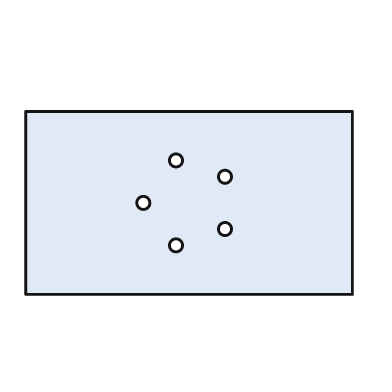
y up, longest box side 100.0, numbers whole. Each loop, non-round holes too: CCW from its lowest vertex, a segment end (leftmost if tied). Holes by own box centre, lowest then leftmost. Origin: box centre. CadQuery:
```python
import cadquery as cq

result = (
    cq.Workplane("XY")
    .moveTo(-50.0, -28.0)
    .lineTo(50.0, -28.0)
    .lineTo(50.0, 28.0)
    .lineTo(-50.0, 28.0)
    .close()
    .moveTo(-4.0, -13.0)
    .circle(2.0)
    .moveTo(11.0, -8.0)
    .circle(2.0)
    .moveTo(-14.0, 0.0)
    .circle(2.0)
    .moveTo(11.0, 8.0)
    .circle(2.0)
    .moveTo(-4.0, 13.0)
    .circle(2.0)
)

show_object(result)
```